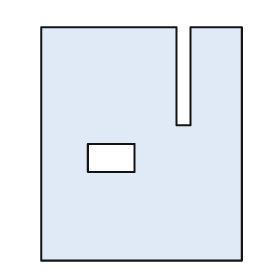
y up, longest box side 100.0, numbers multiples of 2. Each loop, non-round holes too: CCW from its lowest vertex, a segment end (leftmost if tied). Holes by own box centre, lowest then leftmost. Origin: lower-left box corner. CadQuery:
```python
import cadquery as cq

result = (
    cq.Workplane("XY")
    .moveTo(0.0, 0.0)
    .lineTo(86.0, 0.0)
    .lineTo(86.0, 100.0)
    .lineTo(64.0, 100.0)
    .lineTo(64.0, 58.0)
    .lineTo(58.0, 58.0)
    .lineTo(58.0, 100.0)
    .lineTo(0.0, 100.0)
    .close()
    .moveTo(20.0, 38.0)
    .lineTo(40.0, 38.0)
    .lineTo(40.0, 50.0)
    .lineTo(20.0, 50.0)
    .close()
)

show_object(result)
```